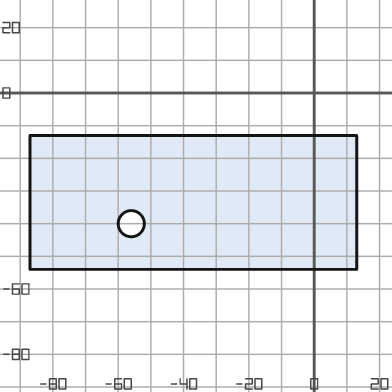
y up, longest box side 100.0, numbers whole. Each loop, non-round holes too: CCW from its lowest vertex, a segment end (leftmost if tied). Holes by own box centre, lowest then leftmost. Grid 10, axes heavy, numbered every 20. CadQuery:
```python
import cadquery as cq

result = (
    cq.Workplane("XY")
    .moveTo(-87.0, -54.0)
    .lineTo(13.0, -54.0)
    .lineTo(13.0, -13.0)
    .lineTo(-87.0, -13.0)
    .close()
    .moveTo(-56.0, -40.0)
    .circle(4.0)
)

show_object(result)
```